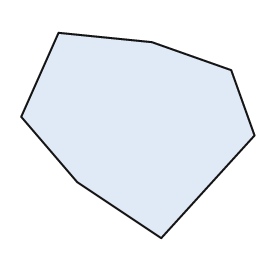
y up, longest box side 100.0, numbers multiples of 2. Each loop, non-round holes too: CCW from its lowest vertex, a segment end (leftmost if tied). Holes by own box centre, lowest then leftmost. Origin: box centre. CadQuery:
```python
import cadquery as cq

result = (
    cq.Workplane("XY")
    .moveTo(10.0, -44.0)
    .lineTo(50.0, 0.0)
    .lineTo(40.0, 28.0)
    .lineTo(6.0, 40.0)
    .lineTo(-34.0, 44.0)
    .lineTo(-50.0, 8.0)
    .lineTo(-26.0, -20.0)
    .close()
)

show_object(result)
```